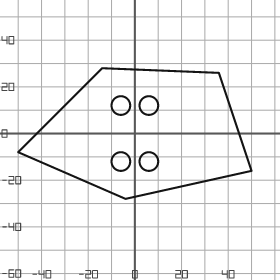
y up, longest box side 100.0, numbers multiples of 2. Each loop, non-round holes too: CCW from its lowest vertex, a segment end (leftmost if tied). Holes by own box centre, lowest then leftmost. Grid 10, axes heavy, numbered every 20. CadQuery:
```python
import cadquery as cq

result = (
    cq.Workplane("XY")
    .moveTo(-4.0, -28.0)
    .lineTo(50.0, -16.0)
    .lineTo(36.0, 26.0)
    .lineTo(-14.0, 28.0)
    .lineTo(-50.0, -8.0)
    .close()
    .moveTo(-6.0, -12.0)
    .circle(4.0)
    .moveTo(6.0, -12.0)
    .circle(4.0)
    .moveTo(-6.0, 12.0)
    .circle(4.0)
    .moveTo(6.0, 12.0)
    .circle(4.0)
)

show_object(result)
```